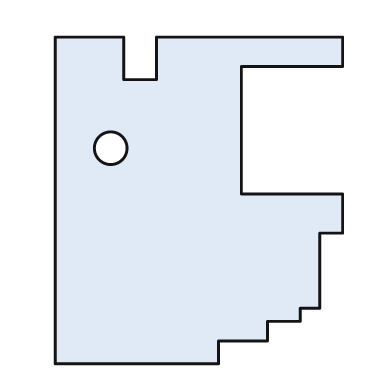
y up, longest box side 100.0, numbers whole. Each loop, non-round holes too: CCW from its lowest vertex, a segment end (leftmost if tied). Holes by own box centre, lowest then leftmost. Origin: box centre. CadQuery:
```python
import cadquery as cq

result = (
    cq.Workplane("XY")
    .moveTo(-44.0, -50.0)
    .lineTo(6.0, -50.0)
    .lineTo(6.0, -43.0)
    .lineTo(21.0, -43.0)
    .lineTo(21.0, -37.0)
    .lineTo(31.0, -37.0)
    .lineTo(31.0, -33.0)
    .lineTo(37.0, -33.0)
    .lineTo(37.0, -10.0)
    .lineTo(44.0, -10.0)
    .lineTo(44.0, 2.0)
    .lineTo(13.0, 2.0)
    .lineTo(13.0, 41.0)
    .lineTo(44.0, 41.0)
    .lineTo(44.0, 50.0)
    .lineTo(-13.0, 50.0)
    .lineTo(-13.0, 37.0)
    .lineTo(-23.0, 37.0)
    .lineTo(-23.0, 50.0)
    .lineTo(-44.0, 50.0)
    .close()
    .moveTo(-27.0, 16.0)
    .circle(5.0)
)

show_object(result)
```